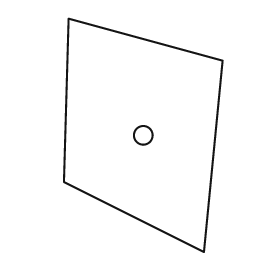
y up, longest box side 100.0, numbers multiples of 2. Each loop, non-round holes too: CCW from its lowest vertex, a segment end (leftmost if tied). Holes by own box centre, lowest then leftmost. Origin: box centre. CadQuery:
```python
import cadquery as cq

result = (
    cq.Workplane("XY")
    .moveTo(26.0, -50.0)
    .lineTo(34.0, 32.0)
    .lineTo(-32.0, 50.0)
    .lineTo(-34.0, -20.0)
    .close()
    .moveTo(0.0, 0.0)
    .circle(4.0)
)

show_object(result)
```